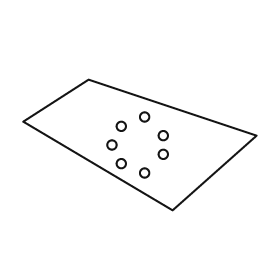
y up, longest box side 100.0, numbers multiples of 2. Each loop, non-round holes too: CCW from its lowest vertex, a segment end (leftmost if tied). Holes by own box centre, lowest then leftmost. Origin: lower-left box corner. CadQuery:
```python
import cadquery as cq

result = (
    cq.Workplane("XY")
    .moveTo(64.0, 0.0)
    .lineTo(100.0, 32.0)
    .lineTo(28.0, 56.0)
    .lineTo(0.0, 38.0)
    .close()
    .moveTo(52.0, 16.0)
    .circle(2.0)
    .moveTo(42.0, 20.0)
    .circle(2.0)
    .moveTo(60.0, 24.0)
    .circle(2.0)
    .moveTo(38.0, 28.0)
    .circle(2.0)
    .moveTo(60.0, 32.0)
    .circle(2.0)
    .moveTo(42.0, 36.0)
    .circle(2.0)
    .moveTo(52.0, 40.0)
    .circle(2.0)
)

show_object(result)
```